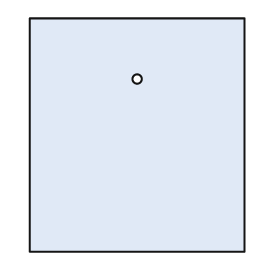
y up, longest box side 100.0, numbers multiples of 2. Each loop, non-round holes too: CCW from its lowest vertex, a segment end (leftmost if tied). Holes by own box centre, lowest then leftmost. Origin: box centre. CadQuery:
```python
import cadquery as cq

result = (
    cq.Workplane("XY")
    .moveTo(-46.0, -50.0)
    .lineTo(46.0, -50.0)
    .lineTo(46.0, 50.0)
    .lineTo(-46.0, 50.0)
    .close()
    .moveTo(0.0, 24.0)
    .circle(2.0)
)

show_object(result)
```